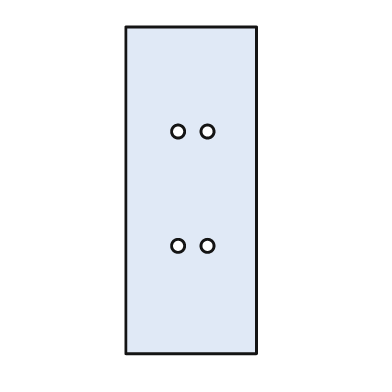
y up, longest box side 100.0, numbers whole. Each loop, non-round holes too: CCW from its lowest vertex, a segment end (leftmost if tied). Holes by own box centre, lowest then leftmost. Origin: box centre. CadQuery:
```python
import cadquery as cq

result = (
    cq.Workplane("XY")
    .moveTo(-20.0, -50.0)
    .lineTo(20.0, -50.0)
    .lineTo(20.0, 50.0)
    .lineTo(-20.0, 50.0)
    .close()
    .moveTo(-4.0, -17.0)
    .circle(2.0)
    .moveTo(5.0, -17.0)
    .circle(2.0)
    .moveTo(-4.0, 18.0)
    .circle(2.0)
    .moveTo(5.0, 18.0)
    .circle(2.0)
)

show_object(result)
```